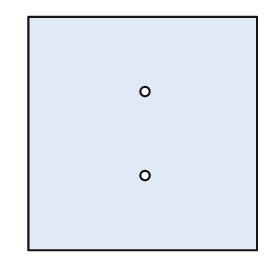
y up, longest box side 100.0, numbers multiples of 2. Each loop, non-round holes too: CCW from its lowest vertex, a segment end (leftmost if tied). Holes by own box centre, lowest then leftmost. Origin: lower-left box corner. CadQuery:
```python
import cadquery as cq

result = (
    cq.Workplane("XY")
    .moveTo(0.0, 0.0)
    .lineTo(98.0, 0.0)
    .lineTo(98.0, 100.0)
    .lineTo(0.0, 100.0)
    .close()
    .moveTo(50.0, 32.0)
    .circle(2.0)
    .moveTo(50.0, 68.0)
    .circle(2.0)
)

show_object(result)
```